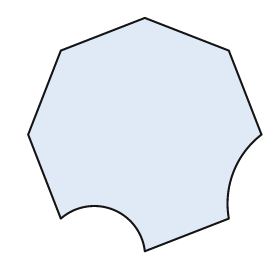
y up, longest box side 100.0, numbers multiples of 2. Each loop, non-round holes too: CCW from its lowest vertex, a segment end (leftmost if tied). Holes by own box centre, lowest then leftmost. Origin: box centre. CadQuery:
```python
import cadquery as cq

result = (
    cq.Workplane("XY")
    .moveTo(0.0, -50.0)
    .lineTo(36.0, -36.0)
    .threePointArc((38.0, -16.0), (50.0, 0.0))
    .lineTo(36.0, 36.0)
    .lineTo(0.0, 50.0)
    .lineTo(-36.0, 36.0)
    .lineTo(-50.0, 0.0)
    .lineTo(-36.0, -36.0)
    .threePointArc((-14.0, -32.0), (0.0, -50.0))
    .close()
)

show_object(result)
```